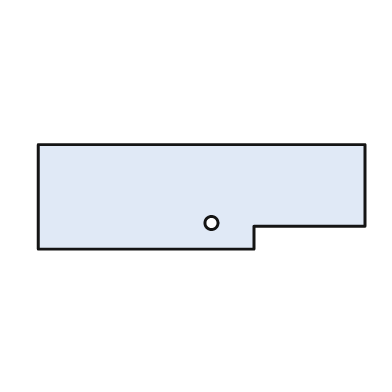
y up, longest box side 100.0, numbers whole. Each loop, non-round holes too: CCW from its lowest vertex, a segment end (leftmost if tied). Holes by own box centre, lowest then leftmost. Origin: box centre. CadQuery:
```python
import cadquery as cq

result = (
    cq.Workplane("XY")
    .moveTo(-50.0, -16.0)
    .lineTo(16.0, -16.0)
    .lineTo(16.0, -9.0)
    .lineTo(50.0, -9.0)
    .lineTo(50.0, 16.0)
    .lineTo(-50.0, 16.0)
    .close()
    .moveTo(3.0, -8.0)
    .circle(2.0)
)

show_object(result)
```